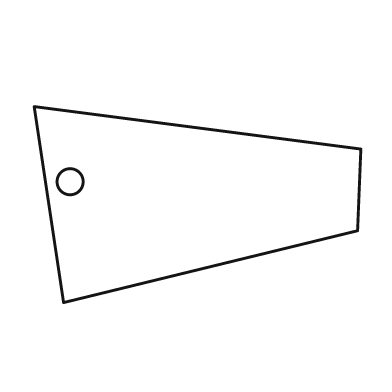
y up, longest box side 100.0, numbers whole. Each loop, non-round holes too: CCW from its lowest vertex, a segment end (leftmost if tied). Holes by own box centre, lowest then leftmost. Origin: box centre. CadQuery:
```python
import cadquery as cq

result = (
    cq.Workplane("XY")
    .moveTo(-41.0, -30.0)
    .lineTo(49.0, -8.0)
    .lineTo(50.0, 17.0)
    .lineTo(-50.0, 30.0)
    .close()
    .moveTo(-39.0, 7.0)
    .circle(4.0)
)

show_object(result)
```